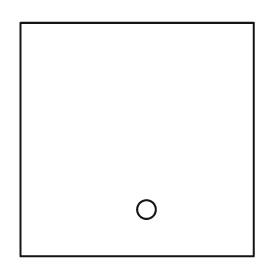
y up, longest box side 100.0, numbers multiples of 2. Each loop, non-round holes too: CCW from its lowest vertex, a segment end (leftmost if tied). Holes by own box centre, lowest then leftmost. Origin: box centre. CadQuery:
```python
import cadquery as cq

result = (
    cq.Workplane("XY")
    .moveTo(-50.0, -50.0)
    .lineTo(50.0, -50.0)
    .lineTo(50.0, 50.0)
    .lineTo(-50.0, 50.0)
    .close()
    .moveTo(4.0, -30.0)
    .circle(4.0)
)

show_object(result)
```